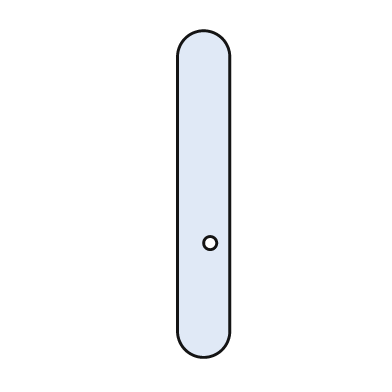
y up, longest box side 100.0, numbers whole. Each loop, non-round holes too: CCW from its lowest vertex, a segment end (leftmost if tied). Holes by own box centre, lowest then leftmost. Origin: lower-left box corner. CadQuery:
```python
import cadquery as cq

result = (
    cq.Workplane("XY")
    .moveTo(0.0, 8.0)
    .threePointArc((8.0, 0.0), (16.0, 8.0))
    .lineTo(16.0, 92.0)
    .threePointArc((8.0, 100.0), (0.0, 92.0))
    .close()
    .moveTo(10.0, 35.0)
    .circle(2.0)
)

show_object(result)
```